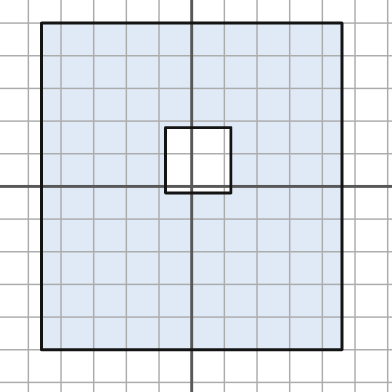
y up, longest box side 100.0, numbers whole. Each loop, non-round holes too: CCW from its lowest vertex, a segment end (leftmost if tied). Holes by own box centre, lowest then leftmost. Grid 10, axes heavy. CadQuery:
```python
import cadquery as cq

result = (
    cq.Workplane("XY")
    .moveTo(-46.0, -50.0)
    .lineTo(46.0, -50.0)
    .lineTo(46.0, 50.0)
    .lineTo(-46.0, 50.0)
    .close()
    .moveTo(-8.0, -2.0)
    .lineTo(12.0, -2.0)
    .lineTo(12.0, 18.0)
    .lineTo(-8.0, 18.0)
    .close()
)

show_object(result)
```